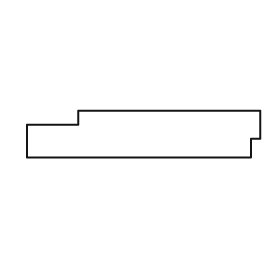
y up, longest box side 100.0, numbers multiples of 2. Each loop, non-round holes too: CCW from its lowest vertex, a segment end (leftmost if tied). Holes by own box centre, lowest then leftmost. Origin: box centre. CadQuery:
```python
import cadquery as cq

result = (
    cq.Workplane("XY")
    .moveTo(-50.0, -10.0)
    .lineTo(46.0, -10.0)
    .lineTo(46.0, -2.0)
    .lineTo(50.0, -2.0)
    .lineTo(50.0, 10.0)
    .lineTo(-28.0, 10.0)
    .lineTo(-28.0, 4.0)
    .lineTo(-50.0, 4.0)
    .close()
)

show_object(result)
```